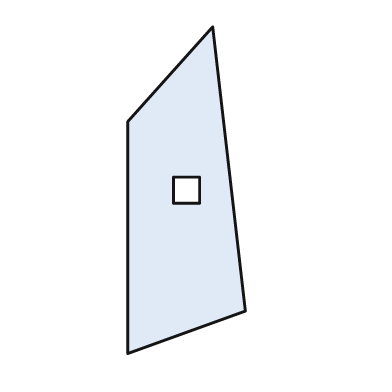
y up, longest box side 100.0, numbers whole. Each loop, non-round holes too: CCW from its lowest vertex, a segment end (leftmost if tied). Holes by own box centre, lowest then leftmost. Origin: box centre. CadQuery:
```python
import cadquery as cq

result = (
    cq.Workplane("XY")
    .moveTo(-18.0, -50.0)
    .lineTo(18.0, -37.0)
    .lineTo(8.0, 50.0)
    .lineTo(-18.0, 21.0)
    .close()
    .moveTo(-4.0, -4.0)
    .lineTo(4.0, -4.0)
    .lineTo(4.0, 4.0)
    .lineTo(-4.0, 4.0)
    .close()
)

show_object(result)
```